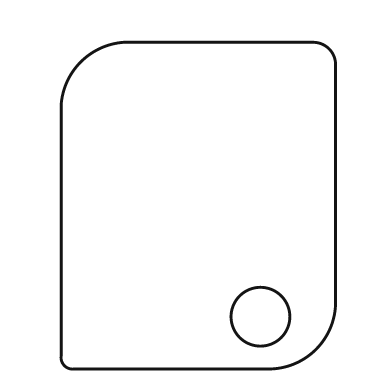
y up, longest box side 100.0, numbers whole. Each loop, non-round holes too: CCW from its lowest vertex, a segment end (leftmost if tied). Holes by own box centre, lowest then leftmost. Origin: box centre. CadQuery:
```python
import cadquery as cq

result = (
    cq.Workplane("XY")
    .moveTo(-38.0, -50.0)
    .lineTo(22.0, -50.0)
    .threePointArc((36.0, -44.0), (42.0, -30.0))
    .lineTo(42.0, 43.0)
    .threePointArc((40.0, 48.0), (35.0, 50.0))
    .lineTo(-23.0, 50.0)
    .threePointArc((-36.0, 44.0), (-42.0, 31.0))
    .lineTo(-42.0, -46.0)
    .threePointArc((-41.0, -49.0), (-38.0, -50.0))
    .close()
    .moveTo(19.0, -34.0)
    .circle(9.0)
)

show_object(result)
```